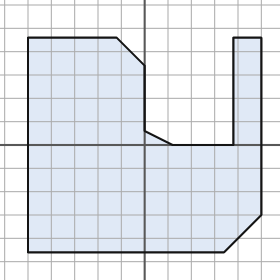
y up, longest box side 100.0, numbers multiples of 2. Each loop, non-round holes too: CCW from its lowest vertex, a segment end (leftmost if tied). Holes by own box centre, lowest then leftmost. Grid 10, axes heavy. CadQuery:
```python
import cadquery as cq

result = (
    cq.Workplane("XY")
    .moveTo(-50.0, -46.0)
    .lineTo(34.0, -46.0)
    .lineTo(50.0, -30.0)
    .lineTo(50.0, 46.0)
    .lineTo(38.0, 46.0)
    .lineTo(38.0, 0.0)
    .lineTo(12.0, 0.0)
    .lineTo(0.0, 6.0)
    .lineTo(0.0, 34.0)
    .lineTo(-12.0, 46.0)
    .lineTo(-50.0, 46.0)
    .close()
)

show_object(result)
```